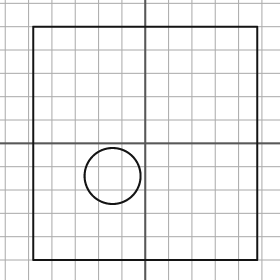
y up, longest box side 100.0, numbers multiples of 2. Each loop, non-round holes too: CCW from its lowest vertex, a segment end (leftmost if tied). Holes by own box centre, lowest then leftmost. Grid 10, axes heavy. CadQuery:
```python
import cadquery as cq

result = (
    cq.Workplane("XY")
    .moveTo(-48.0, -50.0)
    .lineTo(48.0, -50.0)
    .lineTo(48.0, 50.0)
    .lineTo(-48.0, 50.0)
    .close()
    .moveTo(-14.0, -14.0)
    .circle(12.0)
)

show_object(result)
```